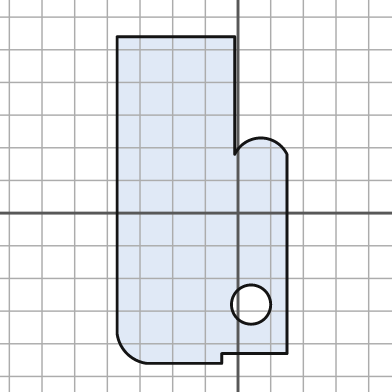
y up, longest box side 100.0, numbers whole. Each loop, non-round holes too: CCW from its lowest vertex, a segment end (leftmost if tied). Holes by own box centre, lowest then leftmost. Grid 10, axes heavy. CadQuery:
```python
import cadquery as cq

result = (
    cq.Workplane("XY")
    .moveTo(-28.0, -46.0)
    .lineTo(-5.0, -46.0)
    .lineTo(-5.0, -43.0)
    .lineTo(15.0, -43.0)
    .lineTo(15.0, 18.0)
    .threePointArc((7.0, 23.0), (-1.0, 18.0))
    .lineTo(-1.0, 54.0)
    .lineTo(-37.0, 54.0)
    .lineTo(-37.0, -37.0)
    .threePointArc((-34.0, -43.0), (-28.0, -46.0))
    .close()
    .moveTo(4.0, -28.0)
    .circle(6.0)
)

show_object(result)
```